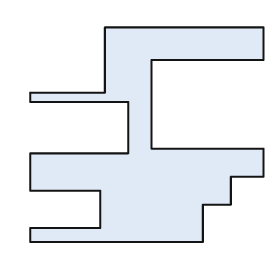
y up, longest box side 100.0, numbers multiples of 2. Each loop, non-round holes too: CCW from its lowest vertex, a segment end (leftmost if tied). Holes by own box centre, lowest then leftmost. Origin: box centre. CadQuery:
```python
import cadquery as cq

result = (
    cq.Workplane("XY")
    .moveTo(-50.0, -46.0)
    .lineTo(24.0, -46.0)
    .lineTo(24.0, -30.0)
    .lineTo(36.0, -30.0)
    .lineTo(36.0, -18.0)
    .lineTo(50.0, -18.0)
    .lineTo(50.0, -6.0)
    .lineTo(2.0, -6.0)
    .lineTo(2.0, 32.0)
    .lineTo(50.0, 32.0)
    .lineTo(50.0, 46.0)
    .lineTo(-18.0, 46.0)
    .lineTo(-18.0, 18.0)
    .lineTo(-50.0, 18.0)
    .lineTo(-50.0, 14.0)
    .lineTo(-8.0, 14.0)
    .lineTo(-8.0, -8.0)
    .lineTo(-50.0, -8.0)
    .lineTo(-50.0, -24.0)
    .lineTo(-20.0, -24.0)
    .lineTo(-20.0, -40.0)
    .lineTo(-50.0, -40.0)
    .close()
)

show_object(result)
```